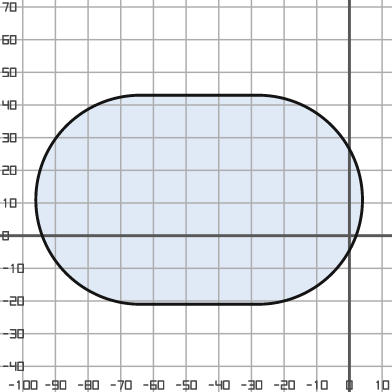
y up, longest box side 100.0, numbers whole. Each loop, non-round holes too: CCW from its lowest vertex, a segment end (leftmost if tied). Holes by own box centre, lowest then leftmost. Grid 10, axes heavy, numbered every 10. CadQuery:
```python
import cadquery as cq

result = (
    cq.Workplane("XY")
    .moveTo(-64.0, -21.0)
    .lineTo(-28.0, -21.0)
    .threePointArc((4.0, 11.0), (-28.0, 43.0))
    .lineTo(-64.0, 43.0)
    .threePointArc((-96.0, 11.0), (-64.0, -21.0))
    .close()
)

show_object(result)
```